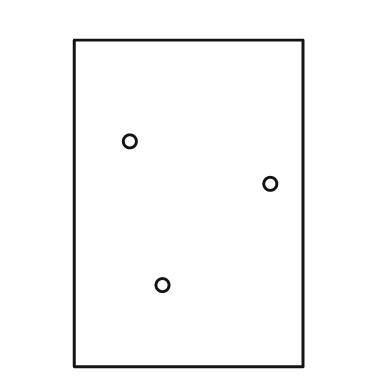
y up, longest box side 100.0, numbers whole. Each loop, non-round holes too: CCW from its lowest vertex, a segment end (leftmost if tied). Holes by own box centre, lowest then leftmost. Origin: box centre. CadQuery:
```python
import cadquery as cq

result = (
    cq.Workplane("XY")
    .moveTo(-35.0, -50.0)
    .lineTo(35.0, -50.0)
    .lineTo(35.0, 50.0)
    .lineTo(-35.0, 50.0)
    .close()
    .moveTo(-8.0, -25.0)
    .circle(2.0)
    .moveTo(25.0, 6.0)
    .circle(2.0)
    .moveTo(-18.0, 19.0)
    .circle(2.0)
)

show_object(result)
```